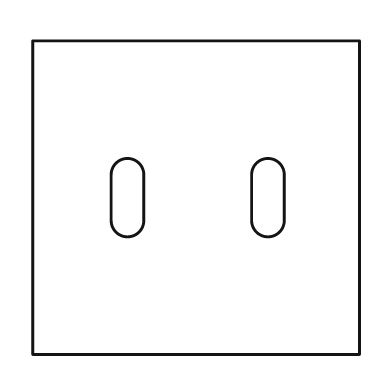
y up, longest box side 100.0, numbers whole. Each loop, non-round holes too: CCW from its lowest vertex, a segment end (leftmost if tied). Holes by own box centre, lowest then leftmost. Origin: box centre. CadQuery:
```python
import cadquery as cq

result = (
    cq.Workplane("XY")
    .moveTo(-50.0, -48.0)
    .lineTo(50.0, -48.0)
    .lineTo(50.0, 48.0)
    .lineTo(-50.0, 48.0)
    .close()
    .moveTo(-26.0, -7.0)
    .threePointArc((-21.0, -12.0), (-16.0, -7.0))
    .lineTo(-16.0, 7.0)
    .threePointArc((-21.0, 12.0), (-26.0, 7.0))
    .close()
    .moveTo(17.0, -7.0)
    .threePointArc((22.0, -12.0), (27.0, -7.0))
    .lineTo(27.0, 7.0)
    .threePointArc((22.0, 12.0), (17.0, 7.0))
    .close()
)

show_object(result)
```